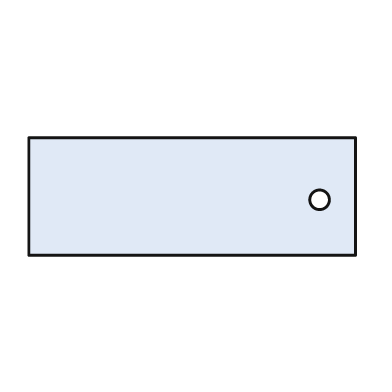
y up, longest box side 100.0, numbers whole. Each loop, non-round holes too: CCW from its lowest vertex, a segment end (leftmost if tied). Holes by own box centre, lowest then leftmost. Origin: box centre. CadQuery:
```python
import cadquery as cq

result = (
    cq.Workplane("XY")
    .moveTo(-50.0, -18.0)
    .lineTo(50.0, -18.0)
    .lineTo(50.0, 18.0)
    .lineTo(-50.0, 18.0)
    .close()
    .moveTo(39.0, -1.0)
    .circle(3.0)
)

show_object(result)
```